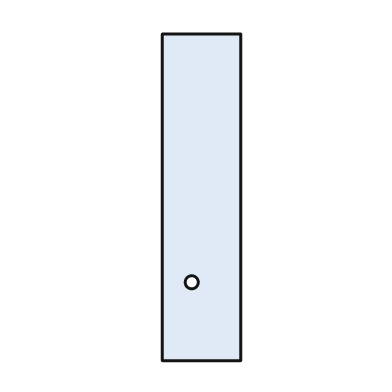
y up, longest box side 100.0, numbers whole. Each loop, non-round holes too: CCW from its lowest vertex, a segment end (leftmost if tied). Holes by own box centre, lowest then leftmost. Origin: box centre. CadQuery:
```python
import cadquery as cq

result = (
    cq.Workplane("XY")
    .moveTo(-12.0, -50.0)
    .lineTo(12.0, -50.0)
    .lineTo(12.0, 50.0)
    .lineTo(-12.0, 50.0)
    .close()
    .moveTo(-3.0, -26.0)
    .circle(2.0)
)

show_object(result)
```